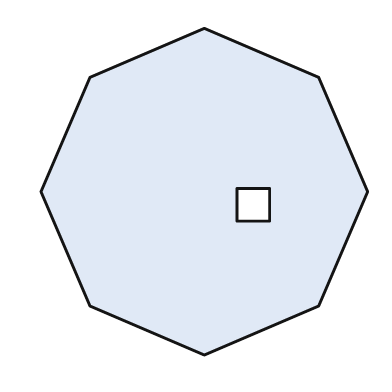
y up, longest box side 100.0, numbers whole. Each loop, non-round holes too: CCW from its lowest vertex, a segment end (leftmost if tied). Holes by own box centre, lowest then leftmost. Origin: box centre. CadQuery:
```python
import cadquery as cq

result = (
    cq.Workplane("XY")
    .moveTo(0.0, -50.0)
    .lineTo(35.0, -35.0)
    .lineTo(50.0, 0.0)
    .lineTo(35.0, 35.0)
    .lineTo(0.0, 50.0)
    .lineTo(-35.0, 35.0)
    .lineTo(-50.0, 0.0)
    .lineTo(-35.0, -35.0)
    .close()
    .moveTo(10.0, -9.0)
    .lineTo(20.0, -9.0)
    .lineTo(20.0, 1.0)
    .lineTo(10.0, 1.0)
    .close()
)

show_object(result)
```